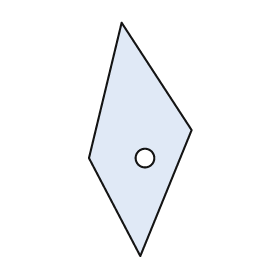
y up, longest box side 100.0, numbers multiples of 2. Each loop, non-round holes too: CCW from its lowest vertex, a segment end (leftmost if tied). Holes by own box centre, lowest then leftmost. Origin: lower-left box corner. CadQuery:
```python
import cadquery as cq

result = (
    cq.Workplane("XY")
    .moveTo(22.0, 0.0)
    .lineTo(44.0, 54.0)
    .lineTo(14.0, 100.0)
    .lineTo(0.0, 42.0)
    .close()
    .moveTo(24.0, 42.0)
    .circle(4.0)
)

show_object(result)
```